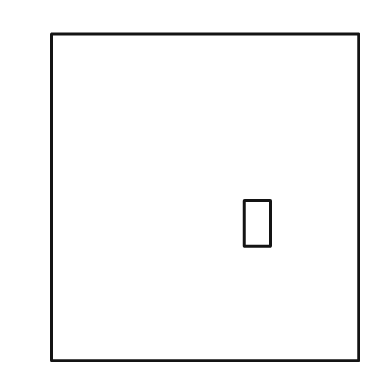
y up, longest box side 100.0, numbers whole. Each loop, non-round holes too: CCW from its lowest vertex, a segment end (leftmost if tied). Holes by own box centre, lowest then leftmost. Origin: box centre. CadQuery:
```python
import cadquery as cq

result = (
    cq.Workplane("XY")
    .moveTo(-47.0, -50.0)
    .lineTo(47.0, -50.0)
    .lineTo(47.0, 50.0)
    .lineTo(-47.0, 50.0)
    .close()
    .moveTo(12.0, -15.0)
    .lineTo(20.0, -15.0)
    .lineTo(20.0, -1.0)
    .lineTo(12.0, -1.0)
    .close()
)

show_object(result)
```